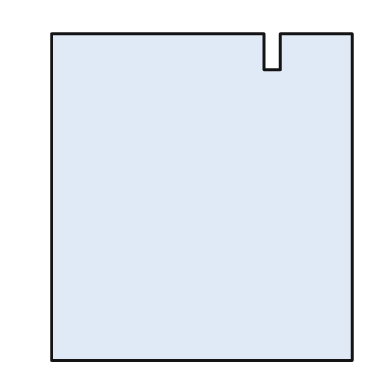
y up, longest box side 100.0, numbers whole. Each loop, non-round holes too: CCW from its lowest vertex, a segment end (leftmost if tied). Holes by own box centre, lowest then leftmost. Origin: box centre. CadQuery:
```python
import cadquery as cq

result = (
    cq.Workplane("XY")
    .moveTo(-46.0, -50.0)
    .lineTo(46.0, -50.0)
    .lineTo(46.0, 50.0)
    .lineTo(24.0, 50.0)
    .lineTo(24.0, 39.0)
    .lineTo(19.0, 39.0)
    .lineTo(19.0, 50.0)
    .lineTo(-46.0, 50.0)
    .close()
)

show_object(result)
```